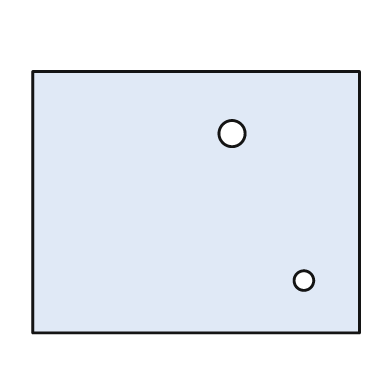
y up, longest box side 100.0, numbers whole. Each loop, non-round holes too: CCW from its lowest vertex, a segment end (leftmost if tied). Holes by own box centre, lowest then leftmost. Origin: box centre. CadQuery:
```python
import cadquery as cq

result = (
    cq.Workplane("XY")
    .moveTo(-50.0, -40.0)
    .lineTo(50.0, -40.0)
    .lineTo(50.0, 40.0)
    .lineTo(-50.0, 40.0)
    .close()
    .moveTo(33.0, -24.0)
    .circle(3.0)
    .moveTo(11.0, 21.0)
    .circle(4.0)
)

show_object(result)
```